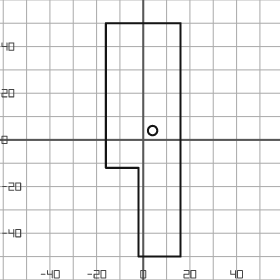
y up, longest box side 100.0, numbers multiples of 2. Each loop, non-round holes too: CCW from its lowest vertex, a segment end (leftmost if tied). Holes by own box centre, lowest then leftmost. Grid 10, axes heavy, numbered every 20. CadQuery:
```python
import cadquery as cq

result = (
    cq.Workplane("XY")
    .moveTo(-2.0, -50.0)
    .lineTo(16.0, -50.0)
    .lineTo(16.0, 50.0)
    .lineTo(-16.0, 50.0)
    .lineTo(-16.0, -12.0)
    .lineTo(-2.0, -12.0)
    .close()
    .moveTo(4.0, 4.0)
    .circle(2.0)
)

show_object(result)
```